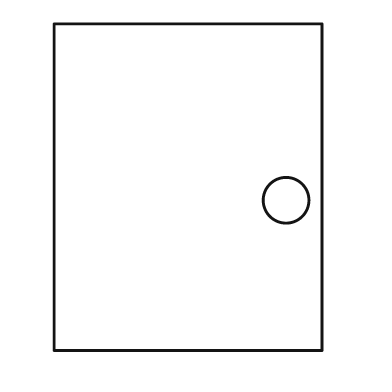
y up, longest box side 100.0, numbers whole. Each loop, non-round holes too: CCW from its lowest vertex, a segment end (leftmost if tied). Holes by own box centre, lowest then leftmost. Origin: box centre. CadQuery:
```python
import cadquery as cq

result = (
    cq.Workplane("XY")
    .moveTo(-41.0, -50.0)
    .lineTo(41.0, -50.0)
    .lineTo(41.0, 50.0)
    .lineTo(-41.0, 50.0)
    .close()
    .moveTo(30.0, -4.0)
    .circle(7.0)
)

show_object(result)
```